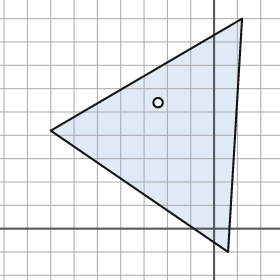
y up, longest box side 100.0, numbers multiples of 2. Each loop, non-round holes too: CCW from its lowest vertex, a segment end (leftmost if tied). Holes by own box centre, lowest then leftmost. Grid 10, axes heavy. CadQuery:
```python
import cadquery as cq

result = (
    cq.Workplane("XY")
    .moveTo(6.0, -10.0)
    .lineTo(12.0, 90.0)
    .lineTo(-70.0, 42.0)
    .close()
    .moveTo(-24.0, 54.0)
    .circle(2.0)
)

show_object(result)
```